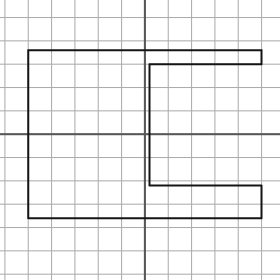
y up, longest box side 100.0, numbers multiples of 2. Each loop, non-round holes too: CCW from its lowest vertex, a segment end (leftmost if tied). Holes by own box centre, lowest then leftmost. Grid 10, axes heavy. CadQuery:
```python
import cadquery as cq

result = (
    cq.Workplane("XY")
    .moveTo(-50.0, -36.0)
    .lineTo(50.0, -36.0)
    .lineTo(50.0, -22.0)
    .lineTo(2.0, -22.0)
    .lineTo(2.0, 30.0)
    .lineTo(50.0, 30.0)
    .lineTo(50.0, 36.0)
    .lineTo(-50.0, 36.0)
    .close()
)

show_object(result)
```